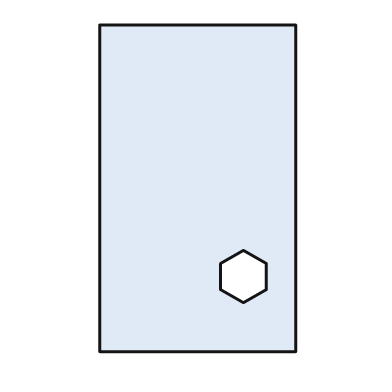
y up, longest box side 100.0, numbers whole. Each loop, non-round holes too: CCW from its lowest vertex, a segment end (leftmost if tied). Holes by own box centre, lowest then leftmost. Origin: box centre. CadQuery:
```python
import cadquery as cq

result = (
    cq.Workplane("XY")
    .moveTo(-30.0, -50.0)
    .lineTo(30.0, -50.0)
    .lineTo(30.0, 50.0)
    .lineTo(-30.0, 50.0)
    .close()
    .moveTo(14.0, -35.0)
    .lineTo(21.0, -31.0)
    .lineTo(21.0, -23.0)
    .lineTo(14.0, -19.0)
    .lineTo(7.0, -23.0)
    .lineTo(7.0, -31.0)
    .close()
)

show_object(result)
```